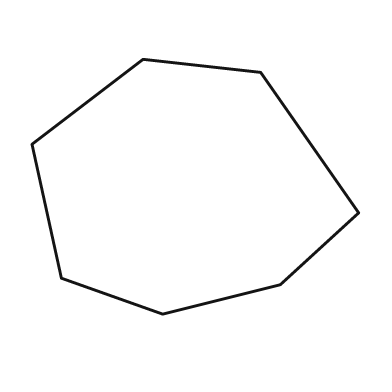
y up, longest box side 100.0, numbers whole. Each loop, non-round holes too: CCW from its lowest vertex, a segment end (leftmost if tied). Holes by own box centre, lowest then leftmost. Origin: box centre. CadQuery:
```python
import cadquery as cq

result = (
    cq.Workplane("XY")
    .moveTo(-10.0, -39.0)
    .lineTo(26.0, -30.0)
    .lineTo(50.0, -8.0)
    .lineTo(20.0, 35.0)
    .lineTo(-16.0, 39.0)
    .lineTo(-50.0, 13.0)
    .lineTo(-41.0, -28.0)
    .close()
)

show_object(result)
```